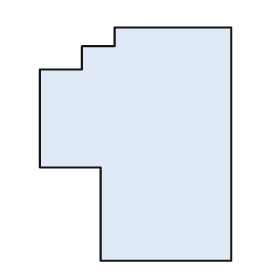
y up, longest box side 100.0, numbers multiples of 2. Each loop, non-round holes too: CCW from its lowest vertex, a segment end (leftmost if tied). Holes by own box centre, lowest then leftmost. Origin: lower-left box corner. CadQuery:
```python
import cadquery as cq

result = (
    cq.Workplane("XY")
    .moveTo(26.0, 0.0)
    .lineTo(82.0, 0.0)
    .lineTo(82.0, 100.0)
    .lineTo(32.0, 100.0)
    .lineTo(32.0, 92.0)
    .lineTo(18.0, 92.0)
    .lineTo(18.0, 82.0)
    .lineTo(0.0, 82.0)
    .lineTo(0.0, 40.0)
    .lineTo(26.0, 40.0)
    .close()
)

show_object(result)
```